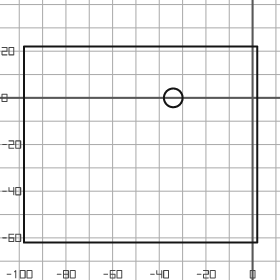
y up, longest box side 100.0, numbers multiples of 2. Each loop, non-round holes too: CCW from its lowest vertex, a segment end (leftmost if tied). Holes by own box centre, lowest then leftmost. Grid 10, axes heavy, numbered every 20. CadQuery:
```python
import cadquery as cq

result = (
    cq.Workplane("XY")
    .moveTo(-98.0, -62.0)
    .lineTo(2.0, -62.0)
    .lineTo(2.0, 22.0)
    .lineTo(-98.0, 22.0)
    .close()
    .moveTo(-34.0, 0.0)
    .circle(4.0)
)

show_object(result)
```